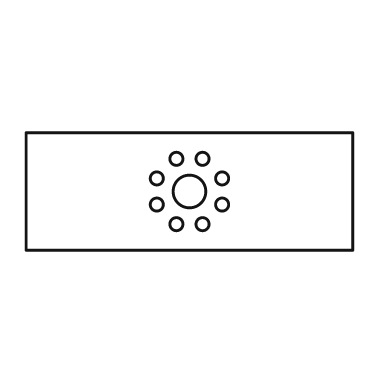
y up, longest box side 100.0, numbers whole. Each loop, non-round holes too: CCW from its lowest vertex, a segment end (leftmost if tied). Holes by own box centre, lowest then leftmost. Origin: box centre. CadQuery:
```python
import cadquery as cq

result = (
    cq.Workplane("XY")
    .moveTo(-50.0, -18.0)
    .lineTo(50.0, -18.0)
    .lineTo(50.0, 18.0)
    .lineTo(-50.0, 18.0)
    .close()
    .moveTo(-4.0, -10.0)
    .circle(2.0)
    .moveTo(4.0, -10.0)
    .circle(2.0)
    .moveTo(-10.0, -4.0)
    .circle(2.0)
    .moveTo(10.0, -4.0)
    .circle(2.0)
    .moveTo(0.0, 0.0)
    .circle(5.0)
    .moveTo(-10.0, 4.0)
    .circle(2.0)
    .moveTo(10.0, 4.0)
    .circle(2.0)
    .moveTo(-4.0, 10.0)
    .circle(2.0)
    .moveTo(4.0, 10.0)
    .circle(2.0)
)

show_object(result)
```